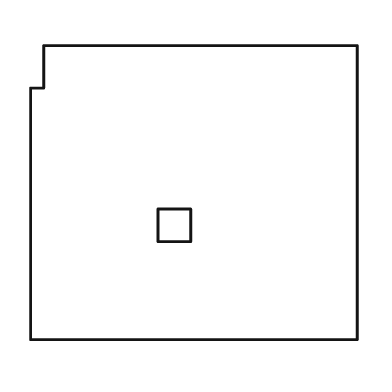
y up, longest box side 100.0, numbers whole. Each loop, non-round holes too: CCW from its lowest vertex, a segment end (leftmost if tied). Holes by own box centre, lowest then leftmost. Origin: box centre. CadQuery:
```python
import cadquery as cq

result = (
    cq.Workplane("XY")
    .moveTo(-50.0, -45.0)
    .lineTo(50.0, -45.0)
    .lineTo(50.0, 45.0)
    .lineTo(-46.0, 45.0)
    .lineTo(-46.0, 32.0)
    .lineTo(-50.0, 32.0)
    .close()
    .moveTo(-11.0, -15.0)
    .lineTo(-1.0, -15.0)
    .lineTo(-1.0, -5.0)
    .lineTo(-11.0, -5.0)
    .close()
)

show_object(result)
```